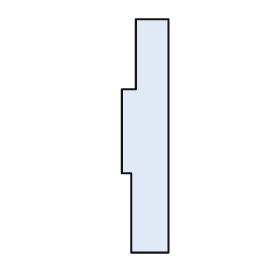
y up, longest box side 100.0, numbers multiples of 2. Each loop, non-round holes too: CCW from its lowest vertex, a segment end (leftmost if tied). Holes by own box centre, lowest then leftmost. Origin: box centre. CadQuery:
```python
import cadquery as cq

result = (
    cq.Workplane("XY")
    .moveTo(-6.0, -50.0)
    .lineTo(10.0, -50.0)
    .lineTo(10.0, 50.0)
    .lineTo(-4.0, 50.0)
    .lineTo(-4.0, 20.0)
    .lineTo(-10.0, 20.0)
    .lineTo(-10.0, -16.0)
    .lineTo(-6.0, -16.0)
    .close()
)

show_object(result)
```